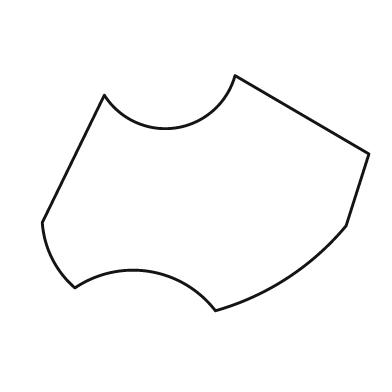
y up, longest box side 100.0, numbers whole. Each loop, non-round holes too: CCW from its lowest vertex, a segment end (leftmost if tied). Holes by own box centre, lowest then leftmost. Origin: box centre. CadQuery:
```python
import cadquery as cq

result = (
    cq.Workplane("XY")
    .moveTo(3.0, -36.0)
    .threePointArc((25.0, -26.0), (43.0, -10.0))
    .lineTo(50.0, 12.0)
    .lineTo(9.0, 36.0)
    .threePointArc((-9.0, 20.0), (-31.0, 30.0))
    .lineTo(-50.0, -9.0)
    .threePointArc((-47.0, -20.0), (-40.0, -29.0))
    .threePointArc((-17.0, -24.0), (3.0, -36.0))
    .close()
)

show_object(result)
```